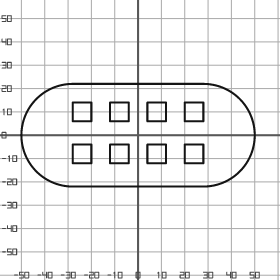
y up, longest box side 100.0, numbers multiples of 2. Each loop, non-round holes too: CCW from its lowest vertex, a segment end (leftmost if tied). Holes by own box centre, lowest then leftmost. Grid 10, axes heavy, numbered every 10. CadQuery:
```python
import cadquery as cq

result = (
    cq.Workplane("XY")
    .moveTo(-28.0, -22.0)
    .lineTo(28.0, -22.0)
    .threePointArc((50.0, 0.0), (28.0, 22.0))
    .lineTo(-28.0, 22.0)
    .threePointArc((-50.0, 0.0), (-28.0, -22.0))
    .close()
    .moveTo(-28.0, -12.0)
    .lineTo(-20.0, -12.0)
    .lineTo(-20.0, -4.0)
    .lineTo(-28.0, -4.0)
    .close()
    .moveTo(-12.0, -12.0)
    .lineTo(-4.0, -12.0)
    .lineTo(-4.0, -4.0)
    .lineTo(-12.0, -4.0)
    .close()
    .moveTo(4.0, -12.0)
    .lineTo(12.0, -12.0)
    .lineTo(12.0, -4.0)
    .lineTo(4.0, -4.0)
    .close()
    .moveTo(20.0, -12.0)
    .lineTo(28.0, -12.0)
    .lineTo(28.0, -4.0)
    .lineTo(20.0, -4.0)
    .close()
    .moveTo(-28.0, 6.0)
    .lineTo(-20.0, 6.0)
    .lineTo(-20.0, 14.0)
    .lineTo(-28.0, 14.0)
    .close()
    .moveTo(-12.0, 6.0)
    .lineTo(-4.0, 6.0)
    .lineTo(-4.0, 14.0)
    .lineTo(-12.0, 14.0)
    .close()
    .moveTo(4.0, 6.0)
    .lineTo(12.0, 6.0)
    .lineTo(12.0, 14.0)
    .lineTo(4.0, 14.0)
    .close()
    .moveTo(20.0, 6.0)
    .lineTo(28.0, 6.0)
    .lineTo(28.0, 14.0)
    .lineTo(20.0, 14.0)
    .close()
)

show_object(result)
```